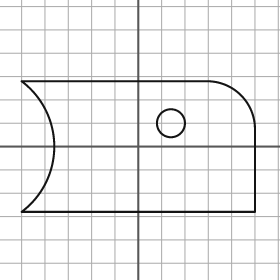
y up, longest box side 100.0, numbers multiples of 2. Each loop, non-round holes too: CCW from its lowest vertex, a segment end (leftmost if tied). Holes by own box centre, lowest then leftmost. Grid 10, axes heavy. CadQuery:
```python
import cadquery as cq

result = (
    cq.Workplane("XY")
    .moveTo(-50.0, -28.0)
    .lineTo(50.0, -28.0)
    .lineTo(50.0, 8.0)
    .threePointArc((44.0, 22.0), (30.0, 28.0))
    .lineTo(-50.0, 28.0)
    .threePointArc((-36.0, 0.0), (-50.0, -28.0))
    .close()
    .moveTo(14.0, 10.0)
    .circle(6.0)
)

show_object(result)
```